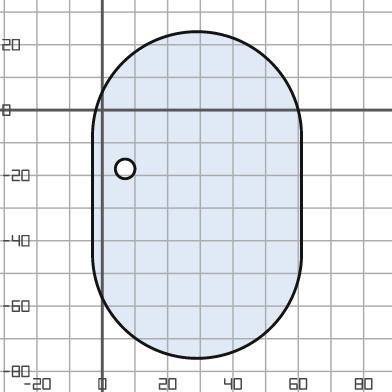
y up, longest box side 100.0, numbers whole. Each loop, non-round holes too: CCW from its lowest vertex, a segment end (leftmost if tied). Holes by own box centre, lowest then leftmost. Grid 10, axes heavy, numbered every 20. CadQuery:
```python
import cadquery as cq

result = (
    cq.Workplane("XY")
    .moveTo(-3.0, -44.0)
    .threePointArc((29.0, -76.0), (61.0, -44.0))
    .lineTo(61.0, -8.0)
    .threePointArc((29.0, 24.0), (-3.0, -8.0))
    .close()
    .moveTo(7.0, -18.0)
    .circle(3.0)
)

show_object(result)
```